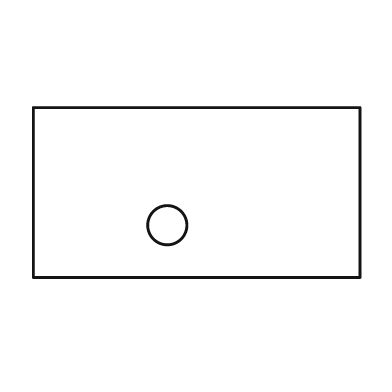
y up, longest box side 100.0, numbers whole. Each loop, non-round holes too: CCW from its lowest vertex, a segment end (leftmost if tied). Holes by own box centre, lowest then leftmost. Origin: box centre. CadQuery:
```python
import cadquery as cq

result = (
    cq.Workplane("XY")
    .moveTo(-50.0, -26.0)
    .lineTo(50.0, -26.0)
    .lineTo(50.0, 26.0)
    .lineTo(-50.0, 26.0)
    .close()
    .moveTo(-9.0, -10.0)
    .circle(6.0)
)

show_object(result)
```